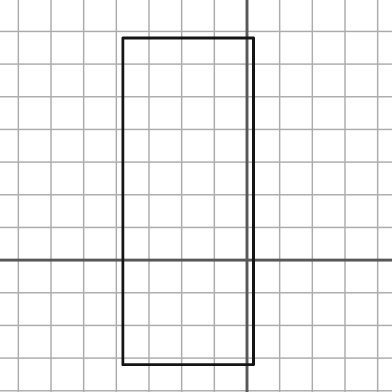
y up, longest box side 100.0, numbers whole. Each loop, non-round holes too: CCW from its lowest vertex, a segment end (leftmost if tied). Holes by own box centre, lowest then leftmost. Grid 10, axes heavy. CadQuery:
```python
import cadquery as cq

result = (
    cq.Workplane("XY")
    .moveTo(-38.0, -32.0)
    .lineTo(2.0, -32.0)
    .lineTo(2.0, 68.0)
    .lineTo(-38.0, 68.0)
    .close()
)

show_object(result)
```